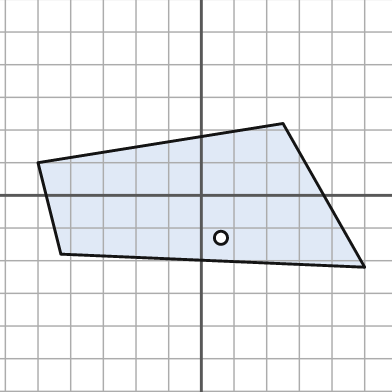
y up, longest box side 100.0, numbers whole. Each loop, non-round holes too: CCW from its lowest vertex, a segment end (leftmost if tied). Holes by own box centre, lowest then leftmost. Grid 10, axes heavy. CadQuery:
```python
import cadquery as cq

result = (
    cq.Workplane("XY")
    .moveTo(50.0, -22.0)
    .lineTo(25.0, 22.0)
    .lineTo(-50.0, 10.0)
    .lineTo(-43.0, -18.0)
    .close()
    .moveTo(6.0, -13.0)
    .circle(2.0)
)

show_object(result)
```